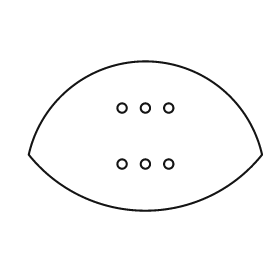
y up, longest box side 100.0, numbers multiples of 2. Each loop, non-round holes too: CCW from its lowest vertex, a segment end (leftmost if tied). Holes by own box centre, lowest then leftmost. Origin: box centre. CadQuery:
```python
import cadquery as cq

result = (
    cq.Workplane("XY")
    .moveTo(-50.0, -8.0)
    .threePointArc((0.0, -32.0), (50.0, -8.0))
    .threePointArc((0.0, 32.0), (-50.0, -8.0))
    .close()
    .moveTo(-10.0, -12.0)
    .circle(2.0)
    .moveTo(0.0, -12.0)
    .circle(2.0)
    .moveTo(10.0, -12.0)
    .circle(2.0)
    .moveTo(-10.0, 12.0)
    .circle(2.0)
    .moveTo(0.0, 12.0)
    .circle(2.0)
    .moveTo(10.0, 12.0)
    .circle(2.0)
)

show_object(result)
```